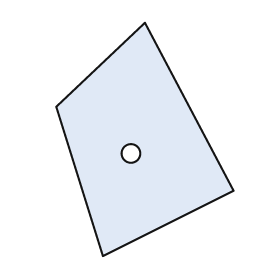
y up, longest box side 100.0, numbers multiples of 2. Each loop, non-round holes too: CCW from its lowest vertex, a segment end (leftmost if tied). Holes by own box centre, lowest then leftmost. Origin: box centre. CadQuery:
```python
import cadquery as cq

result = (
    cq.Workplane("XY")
    .moveTo(-18.0, -50.0)
    .lineTo(38.0, -22.0)
    .lineTo(0.0, 50.0)
    .lineTo(-38.0, 14.0)
    .close()
    .moveTo(-6.0, -6.0)
    .circle(4.0)
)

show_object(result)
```